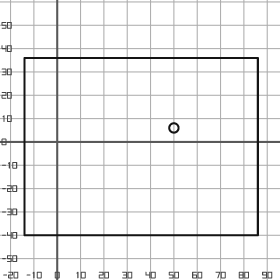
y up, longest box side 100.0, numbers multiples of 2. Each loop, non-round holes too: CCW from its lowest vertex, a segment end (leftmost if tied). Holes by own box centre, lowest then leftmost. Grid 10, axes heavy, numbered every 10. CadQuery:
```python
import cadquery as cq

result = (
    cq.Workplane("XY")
    .moveTo(-14.0, -40.0)
    .lineTo(86.0, -40.0)
    .lineTo(86.0, 36.0)
    .lineTo(-14.0, 36.0)
    .close()
    .moveTo(50.0, 6.0)
    .circle(2.0)
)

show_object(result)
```